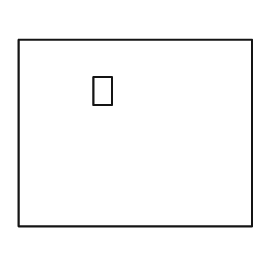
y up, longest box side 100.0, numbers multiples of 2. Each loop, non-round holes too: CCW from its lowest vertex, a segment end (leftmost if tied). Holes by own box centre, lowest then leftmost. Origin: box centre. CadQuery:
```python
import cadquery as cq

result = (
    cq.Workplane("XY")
    .moveTo(-50.0, -40.0)
    .lineTo(50.0, -40.0)
    .lineTo(50.0, 40.0)
    .lineTo(-50.0, 40.0)
    .close()
    .moveTo(-18.0, 12.0)
    .lineTo(-10.0, 12.0)
    .lineTo(-10.0, 24.0)
    .lineTo(-18.0, 24.0)
    .close()
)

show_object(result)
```